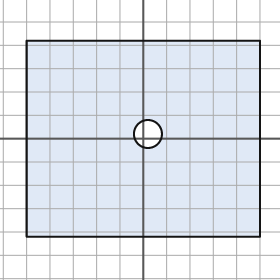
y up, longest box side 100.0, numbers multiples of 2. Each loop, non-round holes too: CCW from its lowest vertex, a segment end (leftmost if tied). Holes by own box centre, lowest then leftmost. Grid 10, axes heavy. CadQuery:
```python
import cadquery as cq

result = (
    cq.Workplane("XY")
    .moveTo(-50.0, -42.0)
    .lineTo(50.0, -42.0)
    .lineTo(50.0, 42.0)
    .lineTo(-50.0, 42.0)
    .close()
    .moveTo(2.0, 2.0)
    .circle(6.0)
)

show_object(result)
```